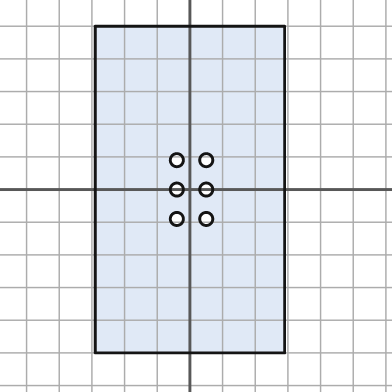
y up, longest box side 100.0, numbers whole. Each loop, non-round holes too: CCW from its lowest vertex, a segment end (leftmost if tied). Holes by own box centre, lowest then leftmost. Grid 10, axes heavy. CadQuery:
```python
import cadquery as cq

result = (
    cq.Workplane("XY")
    .moveTo(-29.0, -50.0)
    .lineTo(29.0, -50.0)
    .lineTo(29.0, 50.0)
    .lineTo(-29.0, 50.0)
    .close()
    .moveTo(-4.0, -9.0)
    .circle(2.0)
    .moveTo(5.0, -9.0)
    .circle(2.0)
    .moveTo(-4.0, 0.0)
    .circle(2.0)
    .moveTo(5.0, 0.0)
    .circle(2.0)
    .moveTo(-4.0, 9.0)
    .circle(2.0)
    .moveTo(5.0, 9.0)
    .circle(2.0)
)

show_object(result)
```